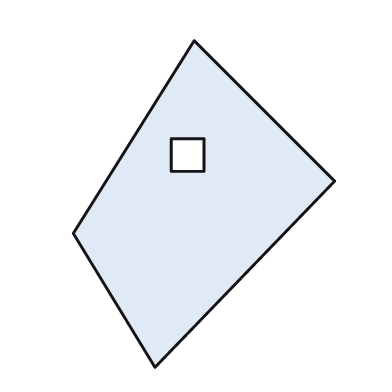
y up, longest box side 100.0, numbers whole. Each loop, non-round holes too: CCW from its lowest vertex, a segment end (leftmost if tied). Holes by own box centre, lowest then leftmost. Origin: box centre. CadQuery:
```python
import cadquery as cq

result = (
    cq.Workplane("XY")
    .moveTo(-15.0, -50.0)
    .lineTo(40.0, 7.0)
    .lineTo(-3.0, 50.0)
    .lineTo(-40.0, -9.0)
    .close()
    .moveTo(-10.0, 10.0)
    .lineTo(0.0, 10.0)
    .lineTo(0.0, 20.0)
    .lineTo(-10.0, 20.0)
    .close()
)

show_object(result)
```